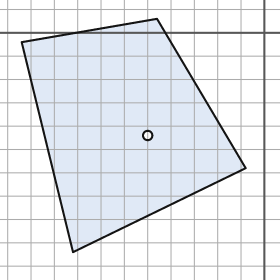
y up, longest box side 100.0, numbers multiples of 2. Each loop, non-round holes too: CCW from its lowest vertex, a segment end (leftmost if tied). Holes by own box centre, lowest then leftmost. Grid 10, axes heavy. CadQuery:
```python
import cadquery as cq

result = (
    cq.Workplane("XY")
    .moveTo(-82.0, -94.0)
    .lineTo(-8.0, -58.0)
    .lineTo(-46.0, 6.0)
    .lineTo(-104.0, -4.0)
    .close()
    .moveTo(-50.0, -44.0)
    .circle(2.0)
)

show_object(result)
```